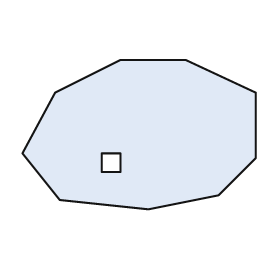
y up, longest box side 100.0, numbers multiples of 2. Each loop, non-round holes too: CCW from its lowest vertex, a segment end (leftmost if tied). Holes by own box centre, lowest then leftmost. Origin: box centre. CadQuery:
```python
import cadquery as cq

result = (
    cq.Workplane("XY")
    .moveTo(4.0, -32.0)
    .lineTo(34.0, -26.0)
    .lineTo(50.0, -10.0)
    .lineTo(50.0, 18.0)
    .lineTo(20.0, 32.0)
    .lineTo(-8.0, 32.0)
    .lineTo(-36.0, 18.0)
    .lineTo(-50.0, -8.0)
    .lineTo(-34.0, -28.0)
    .close()
    .moveTo(-16.0, -16.0)
    .lineTo(-8.0, -16.0)
    .lineTo(-8.0, -8.0)
    .lineTo(-16.0, -8.0)
    .close()
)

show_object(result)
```